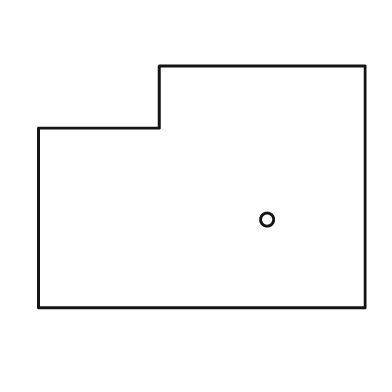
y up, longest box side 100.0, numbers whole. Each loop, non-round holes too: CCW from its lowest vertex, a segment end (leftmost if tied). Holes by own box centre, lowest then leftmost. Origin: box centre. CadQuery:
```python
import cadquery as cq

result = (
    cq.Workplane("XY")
    .moveTo(-50.0, -37.0)
    .lineTo(50.0, -37.0)
    .lineTo(50.0, 37.0)
    .lineTo(-13.0, 37.0)
    .lineTo(-13.0, 18.0)
    .lineTo(-50.0, 18.0)
    .close()
    .moveTo(20.0, -10.0)
    .circle(2.0)
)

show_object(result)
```